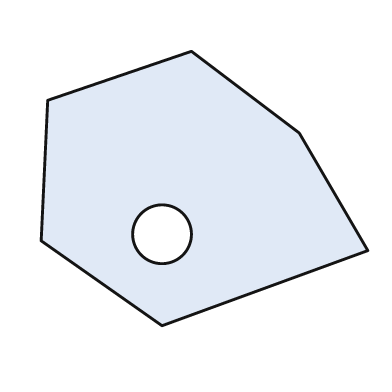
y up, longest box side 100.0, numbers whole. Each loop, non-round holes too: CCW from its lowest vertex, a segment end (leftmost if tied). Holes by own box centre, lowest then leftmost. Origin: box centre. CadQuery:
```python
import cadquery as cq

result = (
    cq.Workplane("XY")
    .moveTo(-13.0, -42.0)
    .lineTo(50.0, -19.0)
    .lineTo(29.0, 17.0)
    .lineTo(-4.0, 42.0)
    .lineTo(-48.0, 27.0)
    .lineTo(-50.0, -16.0)
    .close()
    .moveTo(-13.0, -14.0)
    .circle(9.0)
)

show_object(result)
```